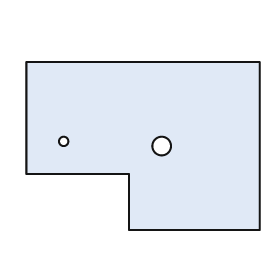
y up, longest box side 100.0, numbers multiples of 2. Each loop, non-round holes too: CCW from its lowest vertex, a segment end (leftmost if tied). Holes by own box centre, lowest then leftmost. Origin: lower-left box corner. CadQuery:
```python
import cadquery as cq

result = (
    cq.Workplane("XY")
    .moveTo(44.0, 0.0)
    .lineTo(100.0, 0.0)
    .lineTo(100.0, 72.0)
    .lineTo(0.0, 72.0)
    .lineTo(0.0, 24.0)
    .lineTo(44.0, 24.0)
    .close()
    .moveTo(58.0, 36.0)
    .circle(4.0)
    .moveTo(16.0, 38.0)
    .circle(2.0)
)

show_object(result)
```